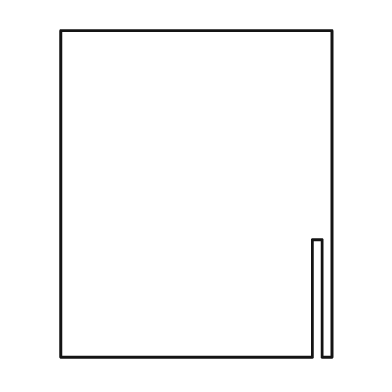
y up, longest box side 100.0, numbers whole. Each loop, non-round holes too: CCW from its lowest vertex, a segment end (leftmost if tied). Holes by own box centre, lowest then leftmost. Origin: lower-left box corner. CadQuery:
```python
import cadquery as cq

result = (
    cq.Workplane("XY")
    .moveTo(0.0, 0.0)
    .lineTo(77.0, 0.0)
    .lineTo(77.0, 36.0)
    .lineTo(80.0, 36.0)
    .lineTo(80.0, 0.0)
    .lineTo(83.0, 0.0)
    .lineTo(83.0, 100.0)
    .lineTo(0.0, 100.0)
    .close()
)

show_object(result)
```